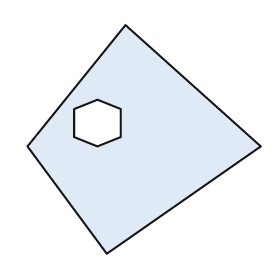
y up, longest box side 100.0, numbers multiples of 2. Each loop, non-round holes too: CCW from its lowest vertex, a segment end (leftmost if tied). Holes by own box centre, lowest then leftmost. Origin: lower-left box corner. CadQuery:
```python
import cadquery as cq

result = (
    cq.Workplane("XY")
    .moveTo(34.0, 0.0)
    .lineTo(100.0, 46.0)
    .lineTo(42.0, 98.0)
    .lineTo(0.0, 46.0)
    .close()
    .moveTo(30.0, 46.0)
    .lineTo(40.0, 50.0)
    .lineTo(40.0, 62.0)
    .lineTo(30.0, 66.0)
    .lineTo(20.0, 62.0)
    .lineTo(20.0, 50.0)
    .close()
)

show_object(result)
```